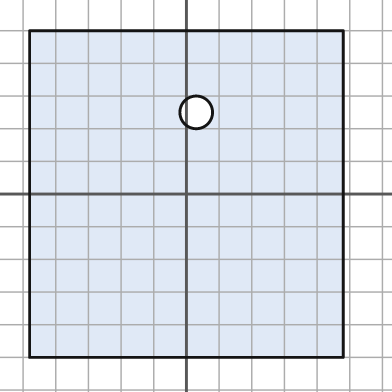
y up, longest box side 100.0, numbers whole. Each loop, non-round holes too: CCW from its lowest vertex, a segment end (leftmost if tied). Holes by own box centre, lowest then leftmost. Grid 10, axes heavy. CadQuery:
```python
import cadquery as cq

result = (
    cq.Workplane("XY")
    .moveTo(-48.0, -50.0)
    .lineTo(48.0, -50.0)
    .lineTo(48.0, 50.0)
    .lineTo(-48.0, 50.0)
    .close()
    .moveTo(3.0, 25.0)
    .circle(5.0)
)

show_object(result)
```